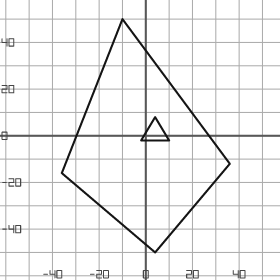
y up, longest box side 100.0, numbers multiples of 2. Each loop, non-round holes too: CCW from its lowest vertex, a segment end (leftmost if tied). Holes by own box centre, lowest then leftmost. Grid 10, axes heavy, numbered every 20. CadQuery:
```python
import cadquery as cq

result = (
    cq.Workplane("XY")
    .moveTo(4.0, -50.0)
    .lineTo(36.0, -12.0)
    .lineTo(-10.0, 50.0)
    .lineTo(-36.0, -16.0)
    .close()
    .moveTo(-2.0, -2.0)
    .lineTo(10.0, -2.0)
    .lineTo(4.0, 8.0)
    .close()
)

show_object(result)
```